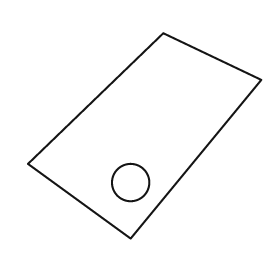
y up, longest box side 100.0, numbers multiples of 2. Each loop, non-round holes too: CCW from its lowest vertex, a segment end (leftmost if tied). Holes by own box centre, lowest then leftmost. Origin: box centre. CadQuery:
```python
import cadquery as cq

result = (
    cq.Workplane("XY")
    .moveTo(-6.0, -44.0)
    .lineTo(50.0, 24.0)
    .lineTo(8.0, 44.0)
    .lineTo(-50.0, -12.0)
    .close()
    .moveTo(-6.0, -20.0)
    .circle(8.0)
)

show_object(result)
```